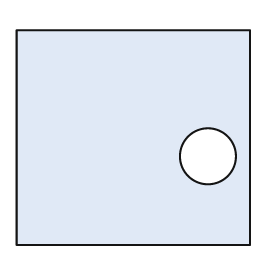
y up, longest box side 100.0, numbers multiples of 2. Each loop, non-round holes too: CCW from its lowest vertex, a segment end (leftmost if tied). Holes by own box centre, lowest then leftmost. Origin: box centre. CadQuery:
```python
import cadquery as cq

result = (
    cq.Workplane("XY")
    .moveTo(-50.0, -46.0)
    .lineTo(50.0, -46.0)
    .lineTo(50.0, 46.0)
    .lineTo(-50.0, 46.0)
    .close()
    .moveTo(32.0, -8.0)
    .circle(12.0)
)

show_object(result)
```